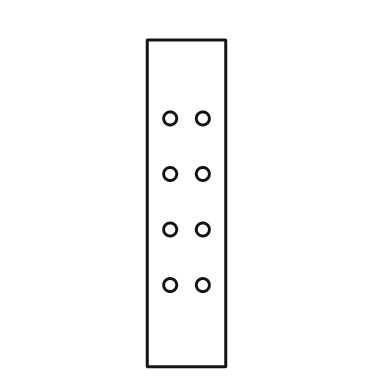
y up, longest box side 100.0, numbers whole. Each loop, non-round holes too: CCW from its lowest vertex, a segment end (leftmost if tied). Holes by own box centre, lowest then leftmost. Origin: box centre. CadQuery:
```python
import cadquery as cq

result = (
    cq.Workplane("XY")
    .moveTo(-12.0, -50.0)
    .lineTo(12.0, -50.0)
    .lineTo(12.0, 50.0)
    .lineTo(-12.0, 50.0)
    .close()
    .moveTo(-5.0, -25.0)
    .circle(2.0)
    .moveTo(5.0, -25.0)
    .circle(2.0)
    .moveTo(-5.0, -8.0)
    .circle(2.0)
    .moveTo(5.0, -8.0)
    .circle(2.0)
    .moveTo(-5.0, 9.0)
    .circle(2.0)
    .moveTo(5.0, 9.0)
    .circle(2.0)
    .moveTo(-5.0, 26.0)
    .circle(2.0)
    .moveTo(5.0, 26.0)
    .circle(2.0)
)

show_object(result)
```